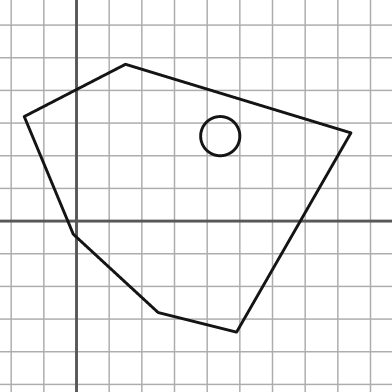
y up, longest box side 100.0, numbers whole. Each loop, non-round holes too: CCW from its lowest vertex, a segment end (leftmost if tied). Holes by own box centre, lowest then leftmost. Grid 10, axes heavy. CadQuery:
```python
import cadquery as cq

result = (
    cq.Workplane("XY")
    .moveTo(49.0, -34.0)
    .lineTo(84.0, 27.0)
    .lineTo(15.0, 48.0)
    .lineTo(-16.0, 32.0)
    .lineTo(-1.0, -4.0)
    .lineTo(25.0, -28.0)
    .close()
    .moveTo(44.0, 26.0)
    .circle(6.0)
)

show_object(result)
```